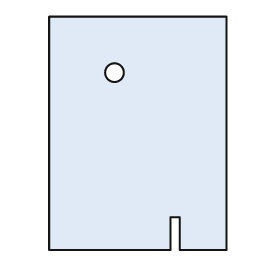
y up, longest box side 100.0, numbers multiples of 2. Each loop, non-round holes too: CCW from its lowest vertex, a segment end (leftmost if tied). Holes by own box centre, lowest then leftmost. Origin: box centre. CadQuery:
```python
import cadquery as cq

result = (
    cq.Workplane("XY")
    .moveTo(-38.0, -50.0)
    .lineTo(14.0, -50.0)
    .lineTo(14.0, -36.0)
    .lineTo(18.0, -36.0)
    .lineTo(18.0, -50.0)
    .lineTo(38.0, -50.0)
    .lineTo(38.0, 50.0)
    .lineTo(-38.0, 50.0)
    .close()
    .moveTo(-10.0, 26.0)
    .circle(4.0)
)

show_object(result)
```